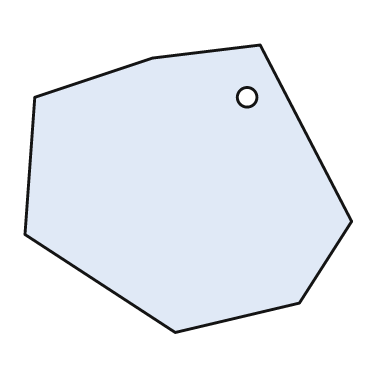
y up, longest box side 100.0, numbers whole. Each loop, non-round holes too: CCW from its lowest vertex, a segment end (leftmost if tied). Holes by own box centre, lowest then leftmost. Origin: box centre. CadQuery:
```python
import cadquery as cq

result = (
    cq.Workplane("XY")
    .moveTo(-4.0, -44.0)
    .lineTo(34.0, -35.0)
    .lineTo(50.0, -10.0)
    .lineTo(22.0, 44.0)
    .lineTo(-11.0, 40.0)
    .lineTo(-47.0, 28.0)
    .lineTo(-50.0, -14.0)
    .close()
    .moveTo(18.0, 28.0)
    .circle(3.0)
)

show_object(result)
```